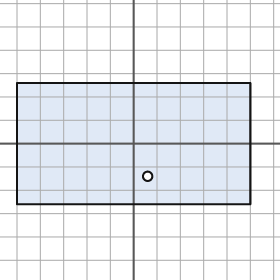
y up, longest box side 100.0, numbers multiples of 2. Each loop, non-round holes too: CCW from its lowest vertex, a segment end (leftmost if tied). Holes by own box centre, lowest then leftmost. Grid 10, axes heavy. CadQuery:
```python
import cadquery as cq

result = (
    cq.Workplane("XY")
    .moveTo(-50.0, -26.0)
    .lineTo(50.0, -26.0)
    .lineTo(50.0, 26.0)
    .lineTo(-50.0, 26.0)
    .close()
    .moveTo(6.0, -14.0)
    .circle(2.0)
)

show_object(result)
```